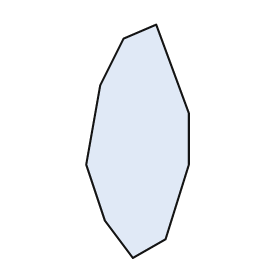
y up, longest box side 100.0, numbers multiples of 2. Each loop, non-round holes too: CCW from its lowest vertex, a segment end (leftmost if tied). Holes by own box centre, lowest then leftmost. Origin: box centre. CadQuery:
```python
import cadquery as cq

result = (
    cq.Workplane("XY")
    .moveTo(-2.0, -50.0)
    .lineTo(12.0, -42.0)
    .lineTo(22.0, -10.0)
    .lineTo(22.0, 12.0)
    .lineTo(8.0, 50.0)
    .lineTo(-6.0, 44.0)
    .lineTo(-16.0, 24.0)
    .lineTo(-22.0, -10.0)
    .lineTo(-14.0, -34.0)
    .close()
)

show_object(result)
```